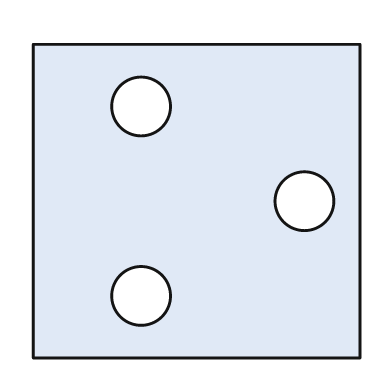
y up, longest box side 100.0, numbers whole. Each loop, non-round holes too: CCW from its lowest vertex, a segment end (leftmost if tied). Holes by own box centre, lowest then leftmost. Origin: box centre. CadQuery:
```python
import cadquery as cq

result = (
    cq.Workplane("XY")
    .moveTo(-50.0, -48.0)
    .lineTo(50.0, -48.0)
    .lineTo(50.0, 48.0)
    .lineTo(-50.0, 48.0)
    .close()
    .moveTo(-17.0, -29.0)
    .circle(9.0)
    .moveTo(33.0, 0.0)
    .circle(9.0)
    .moveTo(-17.0, 29.0)
    .circle(9.0)
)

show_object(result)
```